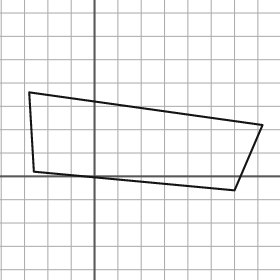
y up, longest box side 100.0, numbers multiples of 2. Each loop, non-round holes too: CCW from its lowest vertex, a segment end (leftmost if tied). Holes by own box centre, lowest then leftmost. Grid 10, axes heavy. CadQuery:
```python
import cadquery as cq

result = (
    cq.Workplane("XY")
    .moveTo(60.0, -6.0)
    .lineTo(72.0, 22.0)
    .lineTo(-28.0, 36.0)
    .lineTo(-26.0, 2.0)
    .close()
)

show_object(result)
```